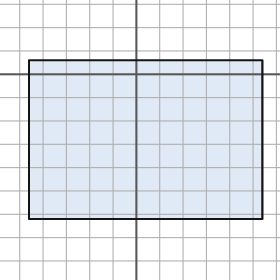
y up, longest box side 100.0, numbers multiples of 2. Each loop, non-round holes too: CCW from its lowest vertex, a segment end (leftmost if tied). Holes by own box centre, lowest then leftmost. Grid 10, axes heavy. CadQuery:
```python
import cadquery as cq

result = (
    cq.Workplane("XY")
    .moveTo(-46.0, -62.0)
    .lineTo(54.0, -62.0)
    .lineTo(54.0, 6.0)
    .lineTo(-46.0, 6.0)
    .close()
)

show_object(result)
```